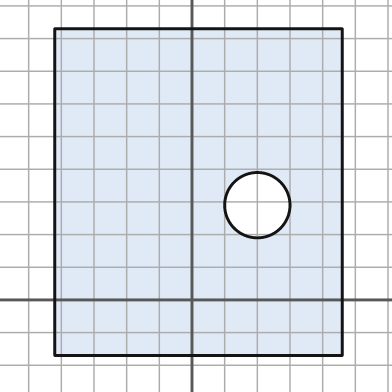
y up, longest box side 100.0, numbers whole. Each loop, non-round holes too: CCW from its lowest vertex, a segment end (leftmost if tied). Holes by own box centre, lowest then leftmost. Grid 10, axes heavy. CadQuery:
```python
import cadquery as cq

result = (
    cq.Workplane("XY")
    .moveTo(-42.0, -17.0)
    .lineTo(46.0, -17.0)
    .lineTo(46.0, 83.0)
    .lineTo(-42.0, 83.0)
    .close()
    .moveTo(20.0, 29.0)
    .circle(10.0)
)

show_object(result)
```